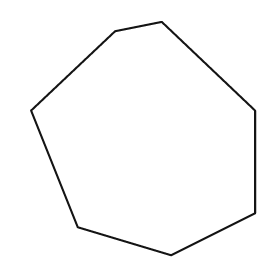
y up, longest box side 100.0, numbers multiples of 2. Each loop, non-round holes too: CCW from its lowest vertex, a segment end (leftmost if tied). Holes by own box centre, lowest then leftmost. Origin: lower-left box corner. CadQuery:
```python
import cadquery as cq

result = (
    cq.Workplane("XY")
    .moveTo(60.0, 0.0)
    .lineTo(96.0, 18.0)
    .lineTo(96.0, 62.0)
    .lineTo(56.0, 100.0)
    .lineTo(36.0, 96.0)
    .lineTo(0.0, 62.0)
    .lineTo(20.0, 12.0)
    .close()
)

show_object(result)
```